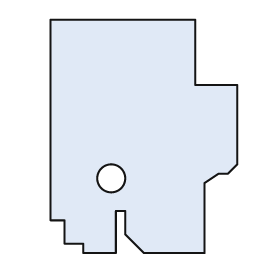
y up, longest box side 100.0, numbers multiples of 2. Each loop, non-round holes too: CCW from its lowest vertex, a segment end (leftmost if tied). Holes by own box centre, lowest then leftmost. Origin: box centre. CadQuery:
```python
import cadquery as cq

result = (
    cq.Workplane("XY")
    .moveTo(-26.0, -50.0)
    .lineTo(-12.0, -50.0)
    .lineTo(-12.0, -32.0)
    .lineTo(-8.0, -32.0)
    .lineTo(-8.0, -42.0)
    .lineTo(0.0, -50.0)
    .lineTo(26.0, -50.0)
    .lineTo(26.0, -20.0)
    .lineTo(32.0, -16.0)
    .lineTo(36.0, -16.0)
    .lineTo(40.0, -12.0)
    .lineTo(40.0, 22.0)
    .lineTo(22.0, 22.0)
    .lineTo(22.0, 50.0)
    .lineTo(-40.0, 50.0)
    .lineTo(-40.0, -36.0)
    .lineTo(-34.0, -36.0)
    .lineTo(-34.0, -46.0)
    .lineTo(-26.0, -46.0)
    .close()
    .moveTo(-14.0, -18.0)
    .circle(6.0)
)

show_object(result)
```